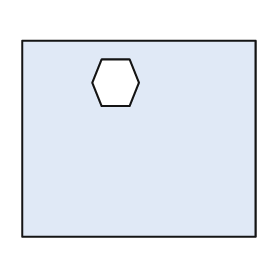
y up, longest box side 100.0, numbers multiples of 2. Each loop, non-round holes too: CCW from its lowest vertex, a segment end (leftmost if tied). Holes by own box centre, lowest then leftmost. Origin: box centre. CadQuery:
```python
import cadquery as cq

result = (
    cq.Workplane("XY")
    .moveTo(-50.0, -42.0)
    .lineTo(50.0, -42.0)
    .lineTo(50.0, 42.0)
    .lineTo(-50.0, 42.0)
    .close()
    .moveTo(-16.0, 14.0)
    .lineTo(-4.0, 14.0)
    .lineTo(0.0, 24.0)
    .lineTo(-4.0, 34.0)
    .lineTo(-16.0, 34.0)
    .lineTo(-20.0, 24.0)
    .close()
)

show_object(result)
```